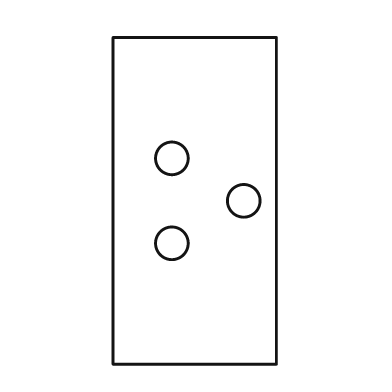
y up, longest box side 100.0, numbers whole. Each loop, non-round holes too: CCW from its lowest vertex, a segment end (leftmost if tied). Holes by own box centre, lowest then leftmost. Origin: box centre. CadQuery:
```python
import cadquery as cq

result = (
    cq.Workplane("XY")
    .moveTo(-25.0, -50.0)
    .lineTo(25.0, -50.0)
    .lineTo(25.0, 50.0)
    .lineTo(-25.0, 50.0)
    .close()
    .moveTo(-7.0, -13.0)
    .circle(5.0)
    .moveTo(15.0, 0.0)
    .circle(5.0)
    .moveTo(-7.0, 13.0)
    .circle(5.0)
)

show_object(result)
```